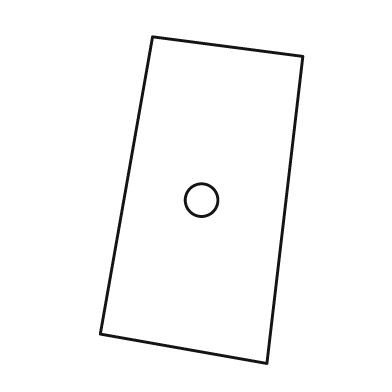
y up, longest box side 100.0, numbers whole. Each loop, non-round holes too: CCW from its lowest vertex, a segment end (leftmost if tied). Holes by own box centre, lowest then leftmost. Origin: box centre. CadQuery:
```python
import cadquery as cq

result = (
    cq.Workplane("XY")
    .moveTo(20.0, -50.0)
    .lineTo(31.0, 44.0)
    .lineTo(-15.0, 50.0)
    .lineTo(-31.0, -41.0)
    .close()
    .moveTo(0.0, 0.0)
    .circle(5.0)
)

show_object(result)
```